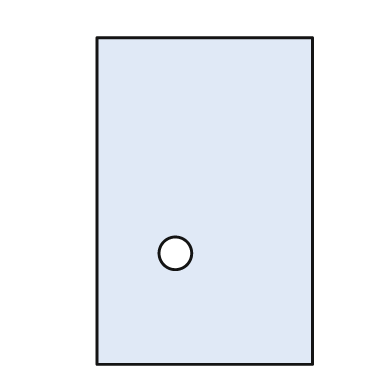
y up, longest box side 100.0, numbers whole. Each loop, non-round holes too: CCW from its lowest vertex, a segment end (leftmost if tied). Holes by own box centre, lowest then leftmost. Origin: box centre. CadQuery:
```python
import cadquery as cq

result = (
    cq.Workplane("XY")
    .moveTo(-33.0, -50.0)
    .lineTo(33.0, -50.0)
    .lineTo(33.0, 50.0)
    .lineTo(-33.0, 50.0)
    .close()
    .moveTo(-9.0, -16.0)
    .circle(5.0)
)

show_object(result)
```